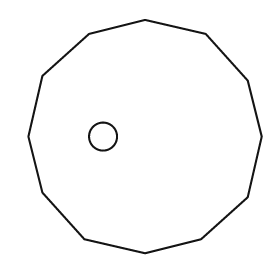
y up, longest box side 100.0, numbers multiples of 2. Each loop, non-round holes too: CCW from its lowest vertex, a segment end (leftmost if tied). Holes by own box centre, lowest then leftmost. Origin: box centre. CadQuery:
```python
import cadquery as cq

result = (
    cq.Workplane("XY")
    .moveTo(0.0, -50.0)
    .lineTo(24.0, -44.0)
    .lineTo(44.0, -26.0)
    .lineTo(50.0, 0.0)
    .lineTo(44.0, 24.0)
    .lineTo(26.0, 44.0)
    .lineTo(0.0, 50.0)
    .lineTo(-24.0, 44.0)
    .lineTo(-44.0, 26.0)
    .lineTo(-50.0, 0.0)
    .lineTo(-44.0, -24.0)
    .lineTo(-26.0, -44.0)
    .close()
    .moveTo(-18.0, 0.0)
    .circle(6.0)
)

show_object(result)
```